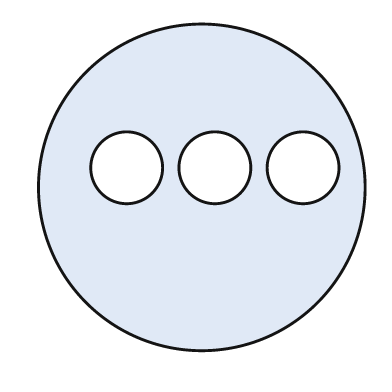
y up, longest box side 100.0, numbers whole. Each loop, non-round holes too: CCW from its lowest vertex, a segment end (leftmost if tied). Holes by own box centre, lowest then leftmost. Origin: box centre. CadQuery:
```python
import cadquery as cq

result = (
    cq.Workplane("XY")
    .moveTo(0.0, 0.0)
    .circle(50.0)
    .moveTo(-23.0, 6.0)
    .circle(11.0)
    .moveTo(4.0, 6.0)
    .circle(11.0)
    .moveTo(31.0, 6.0)
    .circle(11.0)
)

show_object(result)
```